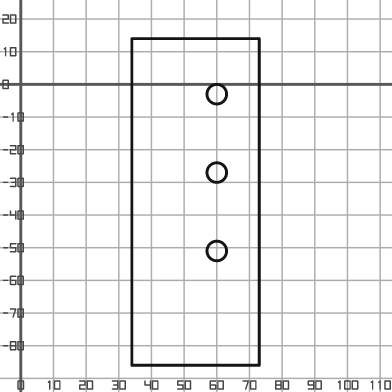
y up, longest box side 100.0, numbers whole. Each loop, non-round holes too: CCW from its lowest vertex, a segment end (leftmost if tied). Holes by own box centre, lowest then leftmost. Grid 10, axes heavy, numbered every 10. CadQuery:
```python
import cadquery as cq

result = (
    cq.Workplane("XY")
    .moveTo(34.0, -86.0)
    .lineTo(73.0, -86.0)
    .lineTo(73.0, 14.0)
    .lineTo(34.0, 14.0)
    .close()
    .moveTo(60.0, -51.0)
    .circle(3.0)
    .moveTo(60.0, -27.0)
    .circle(3.0)
    .moveTo(60.0, -3.0)
    .circle(3.0)
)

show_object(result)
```